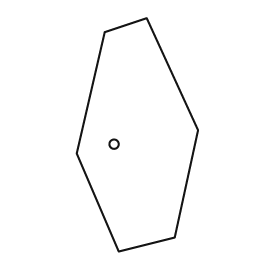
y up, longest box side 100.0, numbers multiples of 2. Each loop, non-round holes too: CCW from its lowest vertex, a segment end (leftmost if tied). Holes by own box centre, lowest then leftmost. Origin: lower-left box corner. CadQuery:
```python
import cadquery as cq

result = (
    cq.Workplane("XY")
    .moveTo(18.0, 0.0)
    .lineTo(42.0, 6.0)
    .lineTo(52.0, 52.0)
    .lineTo(30.0, 100.0)
    .lineTo(12.0, 94.0)
    .lineTo(0.0, 42.0)
    .close()
    .moveTo(16.0, 46.0)
    .circle(2.0)
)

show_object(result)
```